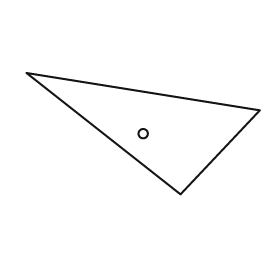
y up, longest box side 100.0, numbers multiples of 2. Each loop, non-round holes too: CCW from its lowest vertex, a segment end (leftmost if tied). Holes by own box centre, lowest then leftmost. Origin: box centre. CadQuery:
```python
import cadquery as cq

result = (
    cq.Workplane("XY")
    .moveTo(16.0, -26.0)
    .lineTo(50.0, 10.0)
    .lineTo(-50.0, 26.0)
    .close()
    .moveTo(0.0, 0.0)
    .circle(2.0)
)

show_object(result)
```